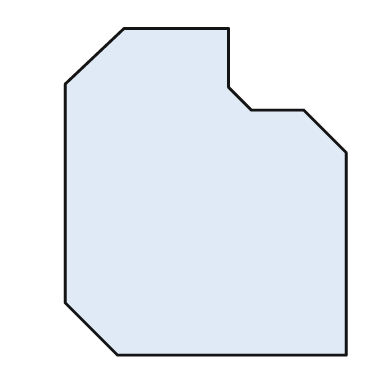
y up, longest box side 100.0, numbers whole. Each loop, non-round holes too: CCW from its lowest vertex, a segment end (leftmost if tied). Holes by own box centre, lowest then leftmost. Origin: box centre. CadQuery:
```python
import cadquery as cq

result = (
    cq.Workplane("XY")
    .moveTo(-27.0, -50.0)
    .lineTo(43.0, -50.0)
    .lineTo(43.0, 12.0)
    .lineTo(30.0, 25.0)
    .lineTo(14.0, 25.0)
    .lineTo(7.0, 32.0)
    .lineTo(7.0, 50.0)
    .lineTo(-25.0, 50.0)
    .lineTo(-43.0, 33.0)
    .lineTo(-43.0, -34.0)
    .close()
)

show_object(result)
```